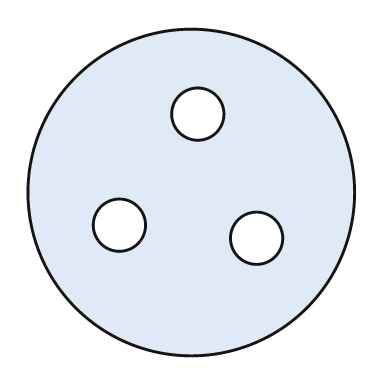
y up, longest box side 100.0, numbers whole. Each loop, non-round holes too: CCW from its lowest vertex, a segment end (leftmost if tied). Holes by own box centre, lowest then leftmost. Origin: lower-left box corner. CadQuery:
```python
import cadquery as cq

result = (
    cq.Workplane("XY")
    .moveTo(50.0, 50.0)
    .circle(50.0)
    .moveTo(70.0, 36.0)
    .circle(8.0)
    .moveTo(28.0, 40.0)
    .circle(8.0)
    .moveTo(52.0, 74.0)
    .circle(8.0)
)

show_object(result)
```